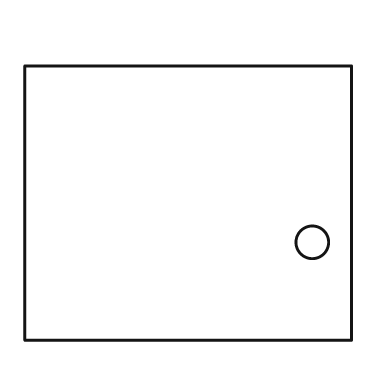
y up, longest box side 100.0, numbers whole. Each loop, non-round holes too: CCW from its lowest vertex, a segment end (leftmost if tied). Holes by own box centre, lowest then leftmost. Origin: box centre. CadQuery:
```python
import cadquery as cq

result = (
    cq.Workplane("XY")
    .moveTo(-50.0, -42.0)
    .lineTo(50.0, -42.0)
    .lineTo(50.0, 42.0)
    .lineTo(-50.0, 42.0)
    .close()
    .moveTo(38.0, -12.0)
    .circle(5.0)
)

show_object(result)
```